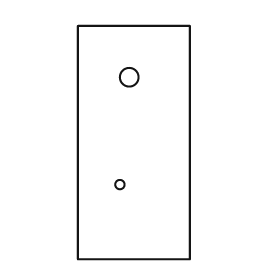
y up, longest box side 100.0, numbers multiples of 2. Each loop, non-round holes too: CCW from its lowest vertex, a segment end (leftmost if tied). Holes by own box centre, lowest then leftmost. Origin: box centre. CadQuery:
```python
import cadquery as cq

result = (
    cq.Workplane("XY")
    .moveTo(-24.0, -50.0)
    .lineTo(24.0, -50.0)
    .lineTo(24.0, 50.0)
    .lineTo(-24.0, 50.0)
    .close()
    .moveTo(-6.0, -18.0)
    .circle(2.0)
    .moveTo(-2.0, 28.0)
    .circle(4.0)
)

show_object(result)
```